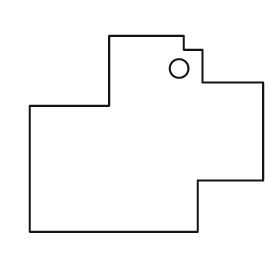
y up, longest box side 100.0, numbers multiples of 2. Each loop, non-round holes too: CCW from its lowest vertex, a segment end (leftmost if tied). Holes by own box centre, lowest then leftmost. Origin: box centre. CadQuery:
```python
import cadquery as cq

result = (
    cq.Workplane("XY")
    .moveTo(-50.0, -42.0)
    .lineTo(22.0, -42.0)
    .lineTo(22.0, -20.0)
    .lineTo(50.0, -20.0)
    .lineTo(50.0, 22.0)
    .lineTo(24.0, 22.0)
    .lineTo(24.0, 36.0)
    .lineTo(16.0, 36.0)
    .lineTo(16.0, 42.0)
    .lineTo(-16.0, 42.0)
    .lineTo(-16.0, 12.0)
    .lineTo(-50.0, 12.0)
    .close()
    .moveTo(14.0, 28.0)
    .circle(4.0)
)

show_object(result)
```